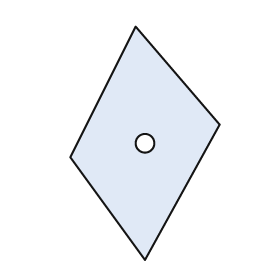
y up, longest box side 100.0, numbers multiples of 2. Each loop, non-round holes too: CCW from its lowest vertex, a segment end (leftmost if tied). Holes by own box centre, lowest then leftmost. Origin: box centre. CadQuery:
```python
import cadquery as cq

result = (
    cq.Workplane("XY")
    .moveTo(0.0, -50.0)
    .lineTo(32.0, 8.0)
    .lineTo(-4.0, 50.0)
    .lineTo(-32.0, -6.0)
    .close()
    .moveTo(0.0, 0.0)
    .circle(4.0)
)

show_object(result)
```